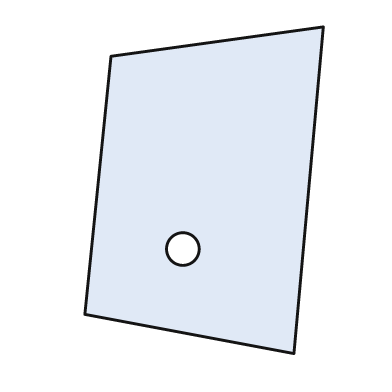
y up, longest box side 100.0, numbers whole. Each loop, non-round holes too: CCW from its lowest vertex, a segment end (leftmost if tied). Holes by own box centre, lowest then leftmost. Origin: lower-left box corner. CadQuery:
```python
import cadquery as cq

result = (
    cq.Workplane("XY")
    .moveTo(64.0, 0.0)
    .lineTo(73.0, 100.0)
    .lineTo(8.0, 91.0)
    .lineTo(0.0, 12.0)
    .close()
    .moveTo(30.0, 32.0)
    .circle(5.0)
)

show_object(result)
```